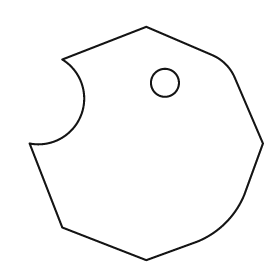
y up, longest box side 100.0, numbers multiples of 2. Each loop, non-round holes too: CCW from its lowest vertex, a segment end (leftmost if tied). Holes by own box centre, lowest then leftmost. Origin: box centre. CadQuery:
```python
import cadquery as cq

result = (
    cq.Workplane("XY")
    .moveTo(0.0, -50.0)
    .lineTo(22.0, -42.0)
    .threePointArc((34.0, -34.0), (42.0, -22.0))
    .lineTo(50.0, 0.0)
    .lineTo(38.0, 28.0)
    .threePointArc((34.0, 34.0), (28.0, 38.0))
    .lineTo(0.0, 50.0)
    .lineTo(-36.0, 36.0)
    .threePointArc((-28.0, 12.0), (-50.0, 0.0))
    .lineTo(-36.0, -36.0)
    .close()
    .moveTo(8.0, 26.0)
    .circle(6.0)
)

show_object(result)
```